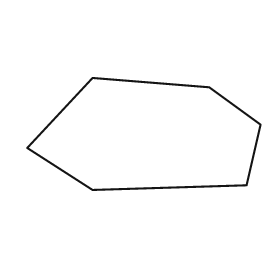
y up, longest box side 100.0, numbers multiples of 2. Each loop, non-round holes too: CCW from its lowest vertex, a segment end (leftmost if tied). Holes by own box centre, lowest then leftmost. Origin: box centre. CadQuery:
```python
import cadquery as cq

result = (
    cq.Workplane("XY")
    .moveTo(-22.0, -24.0)
    .lineTo(44.0, -22.0)
    .lineTo(50.0, 4.0)
    .lineTo(28.0, 20.0)
    .lineTo(-22.0, 24.0)
    .lineTo(-50.0, -6.0)
    .close()
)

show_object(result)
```